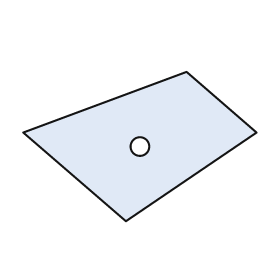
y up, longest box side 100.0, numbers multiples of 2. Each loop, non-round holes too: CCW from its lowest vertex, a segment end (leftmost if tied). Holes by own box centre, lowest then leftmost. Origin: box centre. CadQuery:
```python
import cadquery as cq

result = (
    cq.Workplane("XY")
    .moveTo(-6.0, -32.0)
    .lineTo(50.0, 6.0)
    .lineTo(20.0, 32.0)
    .lineTo(-50.0, 6.0)
    .close()
    .moveTo(0.0, 0.0)
    .circle(4.0)
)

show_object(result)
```